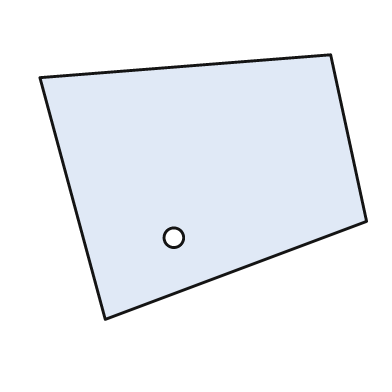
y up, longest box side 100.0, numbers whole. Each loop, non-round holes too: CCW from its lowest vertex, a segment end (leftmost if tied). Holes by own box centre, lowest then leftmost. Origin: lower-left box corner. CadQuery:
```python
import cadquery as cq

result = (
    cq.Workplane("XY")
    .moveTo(20.0, 0.0)
    .lineTo(100.0, 30.0)
    .lineTo(89.0, 81.0)
    .lineTo(0.0, 74.0)
    .close()
    .moveTo(41.0, 25.0)
    .circle(3.0)
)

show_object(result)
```